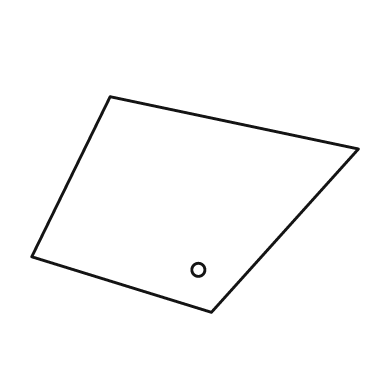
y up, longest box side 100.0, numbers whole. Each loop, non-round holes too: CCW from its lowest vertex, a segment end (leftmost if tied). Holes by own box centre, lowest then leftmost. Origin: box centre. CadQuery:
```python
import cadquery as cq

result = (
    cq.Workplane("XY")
    .moveTo(5.0, -33.0)
    .lineTo(50.0, 17.0)
    .lineTo(-26.0, 33.0)
    .lineTo(-50.0, -16.0)
    .close()
    .moveTo(1.0, -20.0)
    .circle(2.0)
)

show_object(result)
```